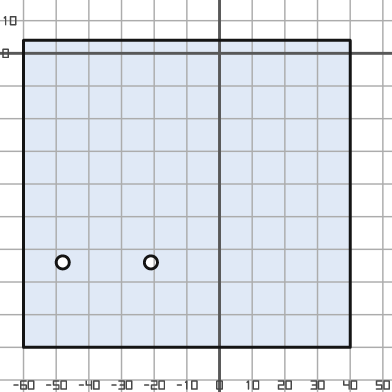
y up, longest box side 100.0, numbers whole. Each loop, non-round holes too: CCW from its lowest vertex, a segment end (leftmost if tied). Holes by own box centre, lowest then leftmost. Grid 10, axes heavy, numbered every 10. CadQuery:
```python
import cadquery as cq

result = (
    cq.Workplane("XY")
    .moveTo(-60.0, -90.0)
    .lineTo(40.0, -90.0)
    .lineTo(40.0, 4.0)
    .lineTo(-60.0, 4.0)
    .close()
    .moveTo(-48.0, -64.0)
    .circle(2.0)
    .moveTo(-21.0, -64.0)
    .circle(2.0)
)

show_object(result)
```